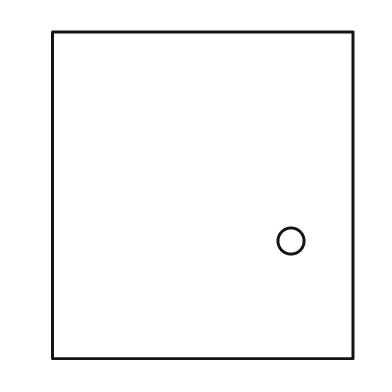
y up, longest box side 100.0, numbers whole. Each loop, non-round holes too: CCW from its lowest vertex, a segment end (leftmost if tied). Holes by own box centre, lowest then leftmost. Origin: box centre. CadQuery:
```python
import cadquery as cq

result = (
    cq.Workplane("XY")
    .moveTo(-46.0, -50.0)
    .lineTo(46.0, -50.0)
    .lineTo(46.0, 50.0)
    .lineTo(-46.0, 50.0)
    .close()
    .moveTo(27.0, -14.0)
    .circle(4.0)
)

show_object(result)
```